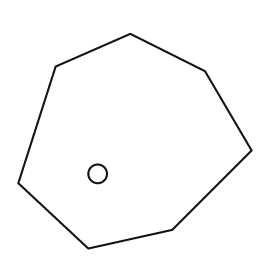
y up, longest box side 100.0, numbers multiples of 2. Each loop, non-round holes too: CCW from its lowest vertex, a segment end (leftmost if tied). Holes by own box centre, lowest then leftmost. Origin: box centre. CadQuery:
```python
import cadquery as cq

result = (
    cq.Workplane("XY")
    .moveTo(-20.0, -46.0)
    .lineTo(16.0, -38.0)
    .lineTo(50.0, -4.0)
    .lineTo(30.0, 30.0)
    .lineTo(-2.0, 46.0)
    .lineTo(-34.0, 32.0)
    .lineTo(-50.0, -18.0)
    .close()
    .moveTo(-16.0, -14.0)
    .circle(4.0)
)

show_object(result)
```